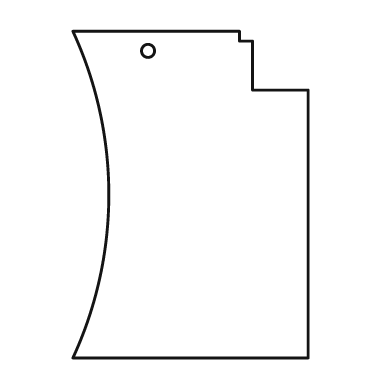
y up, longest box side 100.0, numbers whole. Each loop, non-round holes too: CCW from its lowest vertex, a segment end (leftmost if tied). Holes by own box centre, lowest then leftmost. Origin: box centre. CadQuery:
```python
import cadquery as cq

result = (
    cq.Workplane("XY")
    .moveTo(-36.0, -50.0)
    .lineTo(36.0, -50.0)
    .lineTo(36.0, 32.0)
    .lineTo(19.0, 32.0)
    .lineTo(19.0, 47.0)
    .lineTo(15.0, 47.0)
    .lineTo(15.0, 50.0)
    .lineTo(-36.0, 50.0)
    .threePointArc((-25.0, 0.0), (-36.0, -50.0))
    .close()
    .moveTo(-13.0, 44.0)
    .circle(2.0)
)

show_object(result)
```